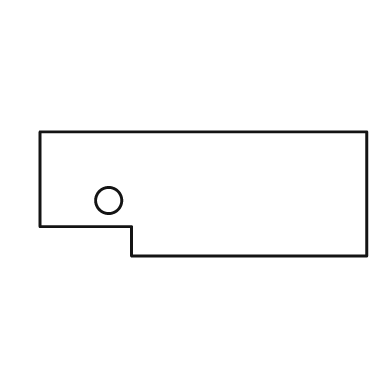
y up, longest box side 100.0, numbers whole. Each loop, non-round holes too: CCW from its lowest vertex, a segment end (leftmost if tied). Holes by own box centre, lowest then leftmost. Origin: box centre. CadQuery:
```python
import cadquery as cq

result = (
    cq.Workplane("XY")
    .moveTo(-22.0, -19.0)
    .lineTo(50.0, -19.0)
    .lineTo(50.0, 19.0)
    .lineTo(-50.0, 19.0)
    .lineTo(-50.0, -10.0)
    .lineTo(-22.0, -10.0)
    .close()
    .moveTo(-29.0, -2.0)
    .circle(4.0)
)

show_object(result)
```